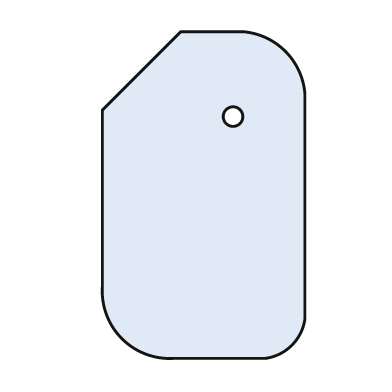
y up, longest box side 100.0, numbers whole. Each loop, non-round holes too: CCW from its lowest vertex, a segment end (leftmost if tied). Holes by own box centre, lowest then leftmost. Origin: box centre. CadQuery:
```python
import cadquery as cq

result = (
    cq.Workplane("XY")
    .moveTo(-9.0, -50.0)
    .lineTo(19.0, -50.0)
    .threePointArc((27.0, -46.0), (31.0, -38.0))
    .lineTo(31.0, 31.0)
    .threePointArc((25.0, 44.0), (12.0, 50.0))
    .lineTo(-7.0, 50.0)
    .lineTo(-31.0, 26.0)
    .lineTo(-31.0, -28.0)
    .threePointArc((-25.0, -44.0), (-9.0, -50.0))
    .close()
    .moveTo(9.0, 24.0)
    .circle(3.0)
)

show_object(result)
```